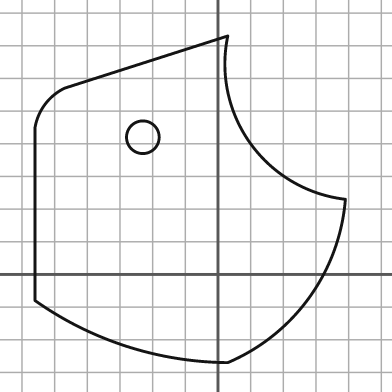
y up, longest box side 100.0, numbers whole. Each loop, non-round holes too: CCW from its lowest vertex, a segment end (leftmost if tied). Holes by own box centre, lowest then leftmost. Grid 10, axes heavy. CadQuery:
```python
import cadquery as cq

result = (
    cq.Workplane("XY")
    .moveTo(3.0, -27.0)
    .threePointArc((28.0, -7.0), (39.0, 23.0))
    .threePointArc((10.0, 40.0), (3.0, 73.0))
    .lineTo(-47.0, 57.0)
    .threePointArc((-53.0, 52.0), (-56.0, 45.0))
    .lineTo(-56.0, -8.0)
    .threePointArc((-28.0, -22.0), (3.0, -27.0))
    .close()
    .moveTo(-23.0, 42.0)
    .circle(5.0)
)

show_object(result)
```